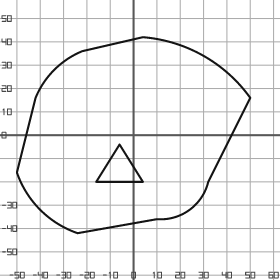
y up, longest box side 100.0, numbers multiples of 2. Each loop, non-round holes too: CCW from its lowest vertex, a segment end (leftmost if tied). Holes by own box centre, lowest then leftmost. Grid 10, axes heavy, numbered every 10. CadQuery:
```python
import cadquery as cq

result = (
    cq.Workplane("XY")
    .moveTo(-24.0, -42.0)
    .lineTo(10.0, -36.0)
    .threePointArc((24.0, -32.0), (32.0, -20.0))
    .lineTo(50.0, 16.0)
    .threePointArc((30.0, 34.0), (4.0, 42.0))
    .lineTo(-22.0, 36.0)
    .threePointArc((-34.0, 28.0), (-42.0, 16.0))
    .lineTo(-50.0, -16.0)
    .threePointArc((-40.0, -32.0), (-24.0, -42.0))
    .close()
    .moveTo(-16.0, -20.0)
    .lineTo(4.0, -20.0)
    .lineTo(-6.0, -4.0)
    .close()
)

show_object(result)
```